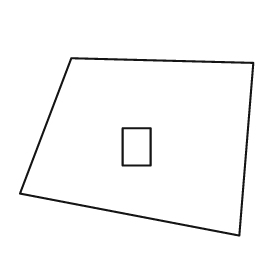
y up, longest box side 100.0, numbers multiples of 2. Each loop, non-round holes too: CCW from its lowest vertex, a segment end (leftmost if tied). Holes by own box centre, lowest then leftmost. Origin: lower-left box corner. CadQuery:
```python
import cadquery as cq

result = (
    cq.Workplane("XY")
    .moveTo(94.0, 0.0)
    .lineTo(100.0, 74.0)
    .lineTo(22.0, 76.0)
    .lineTo(0.0, 18.0)
    .close()
    .moveTo(44.0, 30.0)
    .lineTo(56.0, 30.0)
    .lineTo(56.0, 46.0)
    .lineTo(44.0, 46.0)
    .close()
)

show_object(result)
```